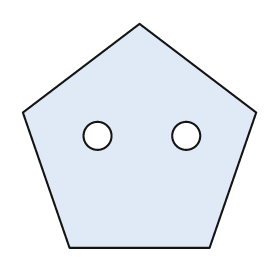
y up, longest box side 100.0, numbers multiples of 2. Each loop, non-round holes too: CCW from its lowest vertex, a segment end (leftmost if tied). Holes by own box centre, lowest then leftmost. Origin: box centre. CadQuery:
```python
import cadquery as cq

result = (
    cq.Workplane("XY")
    .moveTo(-30.0, -48.0)
    .lineTo(30.0, -48.0)
    .lineTo(50.0, 10.0)
    .lineTo(0.0, 48.0)
    .lineTo(-50.0, 10.0)
    .close()
    .moveTo(-18.0, 0.0)
    .circle(6.0)
    .moveTo(20.0, 0.0)
    .circle(6.0)
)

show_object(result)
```